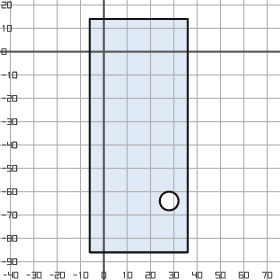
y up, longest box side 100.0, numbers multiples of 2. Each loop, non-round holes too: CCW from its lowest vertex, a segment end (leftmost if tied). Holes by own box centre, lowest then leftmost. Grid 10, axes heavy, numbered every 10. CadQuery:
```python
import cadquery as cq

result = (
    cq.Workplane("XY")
    .moveTo(-6.0, -86.0)
    .lineTo(36.0, -86.0)
    .lineTo(36.0, 14.0)
    .lineTo(-6.0, 14.0)
    .close()
    .moveTo(28.0, -64.0)
    .circle(4.0)
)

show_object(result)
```